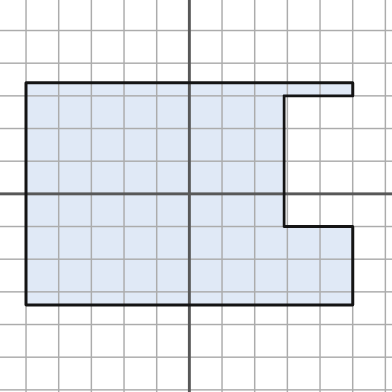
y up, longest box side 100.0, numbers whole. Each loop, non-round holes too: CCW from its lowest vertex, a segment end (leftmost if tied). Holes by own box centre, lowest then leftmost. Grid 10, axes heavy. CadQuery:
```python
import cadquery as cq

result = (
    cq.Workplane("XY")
    .moveTo(-50.0, -34.0)
    .lineTo(50.0, -34.0)
    .lineTo(50.0, -10.0)
    .lineTo(29.0, -10.0)
    .lineTo(29.0, 30.0)
    .lineTo(50.0, 30.0)
    .lineTo(50.0, 34.0)
    .lineTo(-50.0, 34.0)
    .close()
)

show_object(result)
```